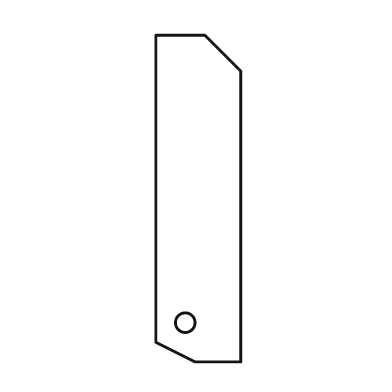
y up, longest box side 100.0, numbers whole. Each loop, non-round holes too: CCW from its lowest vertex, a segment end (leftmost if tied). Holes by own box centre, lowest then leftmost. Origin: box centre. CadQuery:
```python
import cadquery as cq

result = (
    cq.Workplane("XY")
    .moveTo(-1.0, -50.0)
    .lineTo(13.0, -50.0)
    .lineTo(13.0, 39.0)
    .lineTo(2.0, 50.0)
    .lineTo(-13.0, 50.0)
    .lineTo(-13.0, -44.0)
    .close()
    .moveTo(-4.0, -38.0)
    .circle(3.0)
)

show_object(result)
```